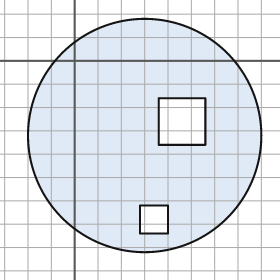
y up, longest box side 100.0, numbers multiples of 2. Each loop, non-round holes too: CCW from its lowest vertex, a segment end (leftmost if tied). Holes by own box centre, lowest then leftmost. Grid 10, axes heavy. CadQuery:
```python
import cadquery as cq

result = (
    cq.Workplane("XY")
    .moveTo(30.0, -32.0)
    .circle(50.0)
    .moveTo(28.0, -74.0)
    .lineTo(40.0, -74.0)
    .lineTo(40.0, -62.0)
    .lineTo(28.0, -62.0)
    .close()
    .moveTo(36.0, -36.0)
    .lineTo(56.0, -36.0)
    .lineTo(56.0, -16.0)
    .lineTo(36.0, -16.0)
    .close()
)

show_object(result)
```